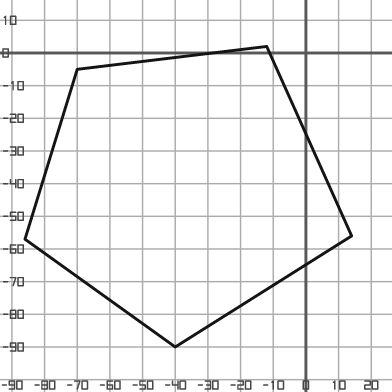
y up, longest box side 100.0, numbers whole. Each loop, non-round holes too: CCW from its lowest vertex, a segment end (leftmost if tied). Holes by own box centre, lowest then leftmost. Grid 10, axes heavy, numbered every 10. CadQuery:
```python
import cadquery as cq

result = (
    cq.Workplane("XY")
    .moveTo(-40.0, -90.0)
    .lineTo(14.0, -56.0)
    .lineTo(-12.0, 2.0)
    .lineTo(-70.0, -5.0)
    .lineTo(-86.0, -57.0)
    .close()
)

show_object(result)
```